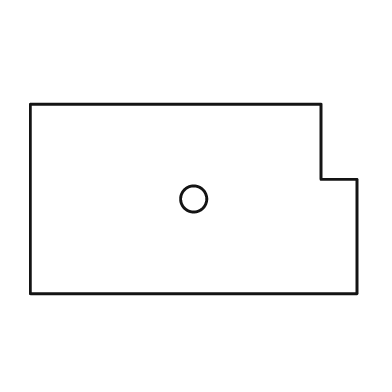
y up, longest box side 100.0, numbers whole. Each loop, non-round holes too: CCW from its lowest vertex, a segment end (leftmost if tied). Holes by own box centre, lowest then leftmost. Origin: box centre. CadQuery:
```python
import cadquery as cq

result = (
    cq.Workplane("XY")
    .moveTo(-50.0, -29.0)
    .lineTo(50.0, -29.0)
    .lineTo(50.0, 6.0)
    .lineTo(39.0, 6.0)
    .lineTo(39.0, 29.0)
    .lineTo(-50.0, 29.0)
    .close()
    .moveTo(0.0, 0.0)
    .circle(4.0)
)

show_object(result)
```